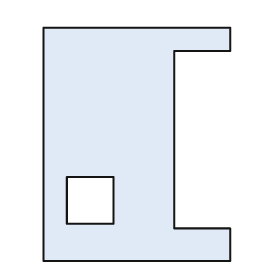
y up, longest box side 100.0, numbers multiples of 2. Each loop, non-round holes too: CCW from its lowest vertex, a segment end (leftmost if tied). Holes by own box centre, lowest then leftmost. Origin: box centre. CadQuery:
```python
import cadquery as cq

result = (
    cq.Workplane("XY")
    .moveTo(-40.0, -50.0)
    .lineTo(40.0, -50.0)
    .lineTo(40.0, -36.0)
    .lineTo(16.0, -36.0)
    .lineTo(16.0, 40.0)
    .lineTo(40.0, 40.0)
    .lineTo(40.0, 50.0)
    .lineTo(-40.0, 50.0)
    .close()
    .moveTo(-30.0, -34.0)
    .lineTo(-10.0, -34.0)
    .lineTo(-10.0, -14.0)
    .lineTo(-30.0, -14.0)
    .close()
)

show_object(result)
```